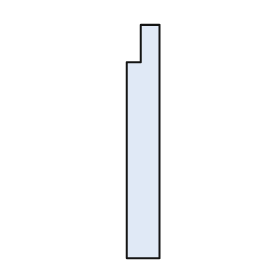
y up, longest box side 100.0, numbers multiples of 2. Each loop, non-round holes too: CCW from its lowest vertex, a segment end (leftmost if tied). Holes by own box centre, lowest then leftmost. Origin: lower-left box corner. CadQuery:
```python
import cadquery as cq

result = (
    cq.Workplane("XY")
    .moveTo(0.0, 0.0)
    .lineTo(14.0, 0.0)
    .lineTo(14.0, 100.0)
    .lineTo(6.0, 100.0)
    .lineTo(6.0, 84.0)
    .lineTo(0.0, 84.0)
    .close()
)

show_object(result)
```